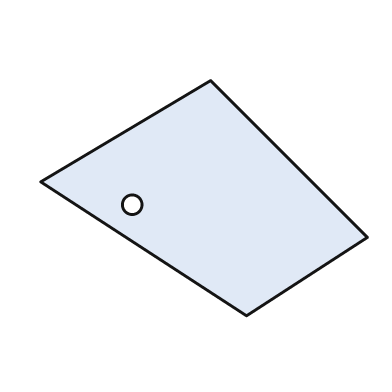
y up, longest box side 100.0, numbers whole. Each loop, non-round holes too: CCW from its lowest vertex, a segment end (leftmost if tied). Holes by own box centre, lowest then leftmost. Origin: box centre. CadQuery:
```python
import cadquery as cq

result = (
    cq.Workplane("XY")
    .moveTo(13.0, -36.0)
    .lineTo(50.0, -12.0)
    .lineTo(2.0, 36.0)
    .lineTo(-50.0, 5.0)
    .close()
    .moveTo(-22.0, -2.0)
    .circle(3.0)
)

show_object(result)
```